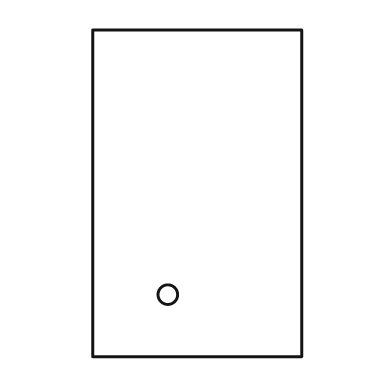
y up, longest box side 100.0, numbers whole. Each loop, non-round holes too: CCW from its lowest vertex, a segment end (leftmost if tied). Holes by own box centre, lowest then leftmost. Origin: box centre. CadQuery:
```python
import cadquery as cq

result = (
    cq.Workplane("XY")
    .moveTo(-32.0, -50.0)
    .lineTo(32.0, -50.0)
    .lineTo(32.0, 50.0)
    .lineTo(-32.0, 50.0)
    .close()
    .moveTo(-9.0, -31.0)
    .circle(3.0)
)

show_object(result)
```